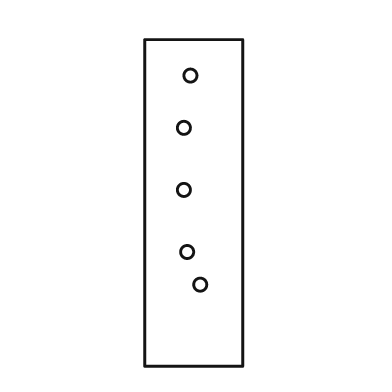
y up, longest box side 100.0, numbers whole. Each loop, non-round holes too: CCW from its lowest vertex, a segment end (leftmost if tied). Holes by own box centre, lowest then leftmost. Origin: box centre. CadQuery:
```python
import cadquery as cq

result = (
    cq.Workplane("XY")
    .moveTo(-15.0, -50.0)
    .lineTo(15.0, -50.0)
    .lineTo(15.0, 50.0)
    .lineTo(-15.0, 50.0)
    .close()
    .moveTo(2.0, -25.0)
    .circle(2.0)
    .moveTo(-2.0, -15.0)
    .circle(2.0)
    .moveTo(-3.0, 4.0)
    .circle(2.0)
    .moveTo(-3.0, 23.0)
    .circle(2.0)
    .moveTo(-1.0, 39.0)
    .circle(2.0)
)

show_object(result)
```